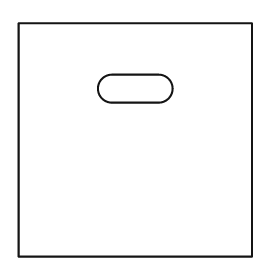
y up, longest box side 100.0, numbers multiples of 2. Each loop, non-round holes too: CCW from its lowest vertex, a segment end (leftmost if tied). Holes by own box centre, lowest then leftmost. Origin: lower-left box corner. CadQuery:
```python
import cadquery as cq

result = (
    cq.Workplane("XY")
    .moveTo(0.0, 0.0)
    .lineTo(100.0, 0.0)
    .lineTo(100.0, 100.0)
    .lineTo(0.0, 100.0)
    .close()
    .moveTo(40.0, 66.0)
    .lineTo(60.0, 66.0)
    .threePointArc((66.0, 72.0), (60.0, 78.0))
    .lineTo(40.0, 78.0)
    .threePointArc((34.0, 72.0), (40.0, 66.0))
    .close()
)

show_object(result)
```